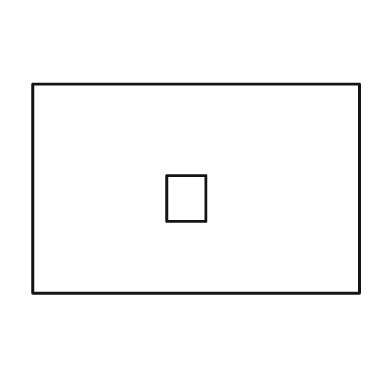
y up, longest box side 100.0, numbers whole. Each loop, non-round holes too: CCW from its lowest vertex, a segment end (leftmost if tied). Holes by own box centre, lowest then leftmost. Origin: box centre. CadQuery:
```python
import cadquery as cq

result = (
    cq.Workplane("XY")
    .moveTo(-50.0, -32.0)
    .lineTo(50.0, -32.0)
    .lineTo(50.0, 32.0)
    .lineTo(-50.0, 32.0)
    .close()
    .moveTo(-9.0, -10.0)
    .lineTo(3.0, -10.0)
    .lineTo(3.0, 4.0)
    .lineTo(-9.0, 4.0)
    .close()
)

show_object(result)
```